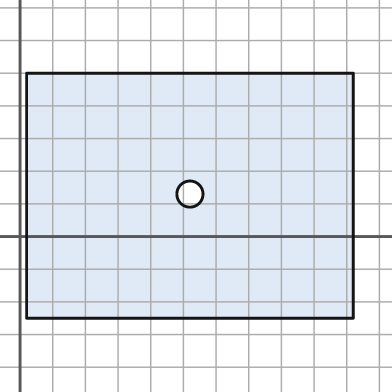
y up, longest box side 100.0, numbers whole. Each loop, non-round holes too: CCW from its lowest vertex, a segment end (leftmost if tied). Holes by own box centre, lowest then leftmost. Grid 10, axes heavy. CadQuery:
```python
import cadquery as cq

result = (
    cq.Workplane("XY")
    .moveTo(2.0, -25.0)
    .lineTo(102.0, -25.0)
    .lineTo(102.0, 50.0)
    .lineTo(2.0, 50.0)
    .close()
    .moveTo(52.0, 13.0)
    .circle(4.0)
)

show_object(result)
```